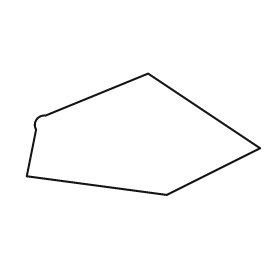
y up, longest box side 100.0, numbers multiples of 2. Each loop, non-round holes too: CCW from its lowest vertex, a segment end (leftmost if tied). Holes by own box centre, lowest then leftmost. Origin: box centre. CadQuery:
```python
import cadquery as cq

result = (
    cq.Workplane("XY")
    .moveTo(10.0, -26.0)
    .lineTo(50.0, -6.0)
    .lineTo(2.0, 26.0)
    .lineTo(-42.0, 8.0)
    .threePointArc((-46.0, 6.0), (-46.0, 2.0))
    .lineTo(-50.0, -18.0)
    .close()
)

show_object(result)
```